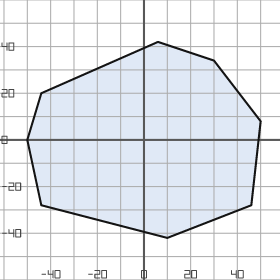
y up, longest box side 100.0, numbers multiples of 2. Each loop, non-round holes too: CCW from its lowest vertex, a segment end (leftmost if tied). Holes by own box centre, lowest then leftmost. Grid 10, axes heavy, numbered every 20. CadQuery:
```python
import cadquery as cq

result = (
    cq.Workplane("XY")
    .moveTo(10.0, -42.0)
    .lineTo(46.0, -28.0)
    .lineTo(50.0, 8.0)
    .lineTo(30.0, 34.0)
    .lineTo(6.0, 42.0)
    .lineTo(-44.0, 20.0)
    .lineTo(-50.0, 0.0)
    .lineTo(-44.0, -28.0)
    .close()
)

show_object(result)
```